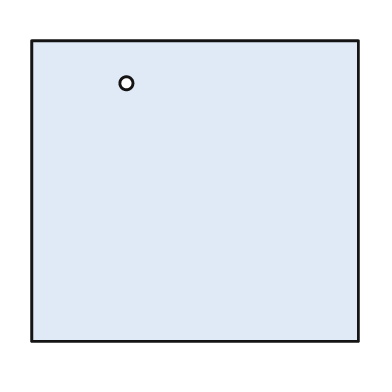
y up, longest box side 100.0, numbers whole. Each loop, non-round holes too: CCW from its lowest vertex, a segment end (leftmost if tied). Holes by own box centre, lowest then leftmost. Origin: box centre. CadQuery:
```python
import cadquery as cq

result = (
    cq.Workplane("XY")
    .moveTo(-50.0, -46.0)
    .lineTo(50.0, -46.0)
    .lineTo(50.0, 46.0)
    .lineTo(-50.0, 46.0)
    .close()
    .moveTo(-21.0, 33.0)
    .circle(2.0)
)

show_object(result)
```